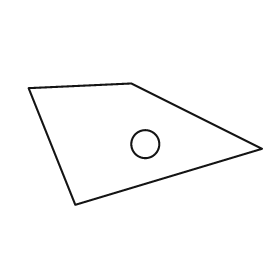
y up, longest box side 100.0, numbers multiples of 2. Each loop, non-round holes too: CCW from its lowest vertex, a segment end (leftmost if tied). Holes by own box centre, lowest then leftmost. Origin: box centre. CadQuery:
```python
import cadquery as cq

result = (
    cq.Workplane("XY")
    .moveTo(-30.0, -26.0)
    .lineTo(50.0, -2.0)
    .lineTo(-6.0, 26.0)
    .lineTo(-50.0, 24.0)
    .close()
    .moveTo(0.0, 0.0)
    .circle(6.0)
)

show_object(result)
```